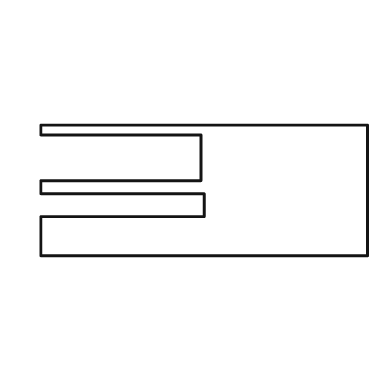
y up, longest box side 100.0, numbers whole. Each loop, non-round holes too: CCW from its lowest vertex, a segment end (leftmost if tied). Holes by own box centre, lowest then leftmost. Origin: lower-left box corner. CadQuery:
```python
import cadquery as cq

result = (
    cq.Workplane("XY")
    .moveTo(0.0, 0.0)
    .lineTo(100.0, 0.0)
    .lineTo(100.0, 40.0)
    .lineTo(0.0, 40.0)
    .lineTo(0.0, 37.0)
    .lineTo(49.0, 37.0)
    .lineTo(49.0, 23.0)
    .lineTo(0.0, 23.0)
    .lineTo(0.0, 19.0)
    .lineTo(50.0, 19.0)
    .lineTo(50.0, 12.0)
    .lineTo(0.0, 12.0)
    .close()
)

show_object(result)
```